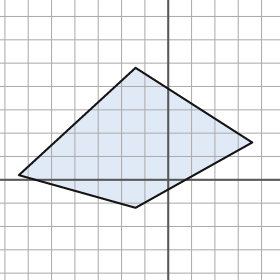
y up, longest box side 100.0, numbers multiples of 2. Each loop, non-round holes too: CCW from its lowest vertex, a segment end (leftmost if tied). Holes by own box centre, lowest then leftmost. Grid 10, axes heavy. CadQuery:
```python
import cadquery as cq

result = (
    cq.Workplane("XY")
    .moveTo(-14.0, -12.0)
    .lineTo(36.0, 16.0)
    .lineTo(-14.0, 48.0)
    .lineTo(-64.0, 2.0)
    .close()
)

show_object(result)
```